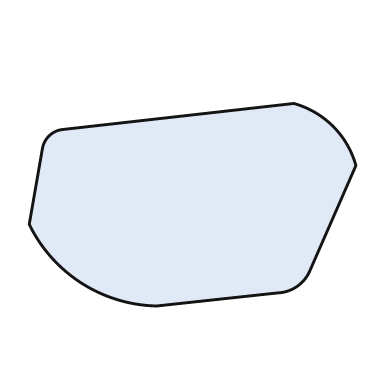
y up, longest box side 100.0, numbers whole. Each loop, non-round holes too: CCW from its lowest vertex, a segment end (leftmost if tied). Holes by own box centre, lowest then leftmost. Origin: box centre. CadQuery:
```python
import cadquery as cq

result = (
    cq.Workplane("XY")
    .moveTo(-11.0, -31.0)
    .lineTo(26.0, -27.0)
    .threePointArc((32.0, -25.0), (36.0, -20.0))
    .lineTo(50.0, 12.0)
    .threePointArc((43.0, 24.0), (31.0, 31.0))
    .lineTo(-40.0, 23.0)
    .threePointArc((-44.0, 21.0), (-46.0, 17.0))
    .lineTo(-50.0, -6.0)
    .threePointArc((-34.0, -24.0), (-11.0, -31.0))
    .close()
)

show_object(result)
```